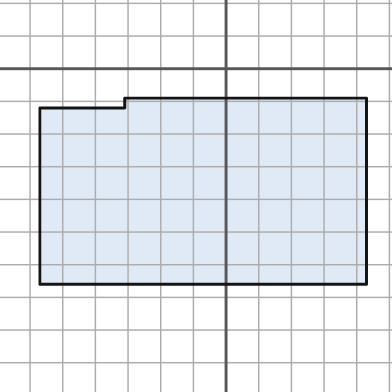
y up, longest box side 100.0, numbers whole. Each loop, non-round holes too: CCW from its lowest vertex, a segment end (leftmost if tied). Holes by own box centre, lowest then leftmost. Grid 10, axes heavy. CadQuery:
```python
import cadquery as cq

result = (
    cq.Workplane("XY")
    .moveTo(-57.0, -66.0)
    .lineTo(43.0, -66.0)
    .lineTo(43.0, -9.0)
    .lineTo(-31.0, -9.0)
    .lineTo(-31.0, -12.0)
    .lineTo(-57.0, -12.0)
    .close()
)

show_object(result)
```